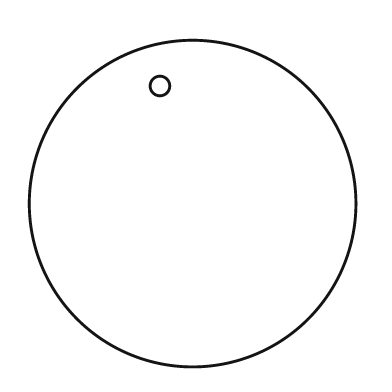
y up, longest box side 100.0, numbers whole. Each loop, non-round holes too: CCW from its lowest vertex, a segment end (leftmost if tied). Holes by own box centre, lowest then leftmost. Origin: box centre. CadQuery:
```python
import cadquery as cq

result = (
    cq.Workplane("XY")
    .moveTo(0.0, 0.0)
    .circle(50.0)
    .moveTo(-10.0, 36.0)
    .circle(3.0)
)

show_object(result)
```